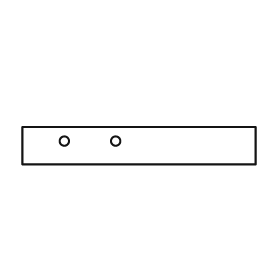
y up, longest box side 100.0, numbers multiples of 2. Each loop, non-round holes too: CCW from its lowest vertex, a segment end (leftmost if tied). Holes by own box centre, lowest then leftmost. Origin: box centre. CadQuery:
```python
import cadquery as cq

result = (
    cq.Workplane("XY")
    .moveTo(-50.0, -8.0)
    .lineTo(50.0, -8.0)
    .lineTo(50.0, 8.0)
    .lineTo(-50.0, 8.0)
    .close()
    .moveTo(-32.0, 2.0)
    .circle(2.0)
    .moveTo(-10.0, 2.0)
    .circle(2.0)
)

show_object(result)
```